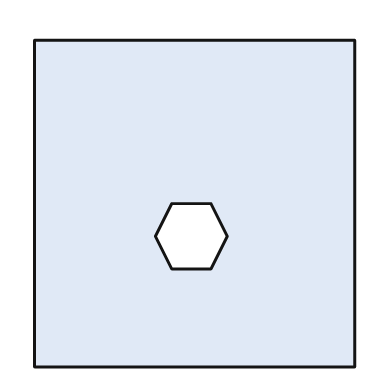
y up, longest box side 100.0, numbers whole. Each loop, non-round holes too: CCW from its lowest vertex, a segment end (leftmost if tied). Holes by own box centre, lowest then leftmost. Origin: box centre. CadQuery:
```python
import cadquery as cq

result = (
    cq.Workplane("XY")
    .moveTo(-49.0, -50.0)
    .lineTo(49.0, -50.0)
    .lineTo(49.0, 50.0)
    .lineTo(-49.0, 50.0)
    .close()
    .moveTo(-7.0, -20.0)
    .lineTo(5.0, -20.0)
    .lineTo(10.0, -10.0)
    .lineTo(5.0, 0.0)
    .lineTo(-7.0, 0.0)
    .lineTo(-12.0, -10.0)
    .close()
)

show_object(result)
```